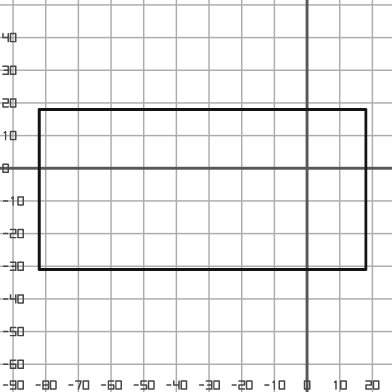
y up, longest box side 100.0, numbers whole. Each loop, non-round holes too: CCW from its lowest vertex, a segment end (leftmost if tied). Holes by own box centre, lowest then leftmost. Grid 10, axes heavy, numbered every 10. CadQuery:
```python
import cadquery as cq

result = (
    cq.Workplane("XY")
    .moveTo(-82.0, -31.0)
    .lineTo(18.0, -31.0)
    .lineTo(18.0, 18.0)
    .lineTo(-82.0, 18.0)
    .close()
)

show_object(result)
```